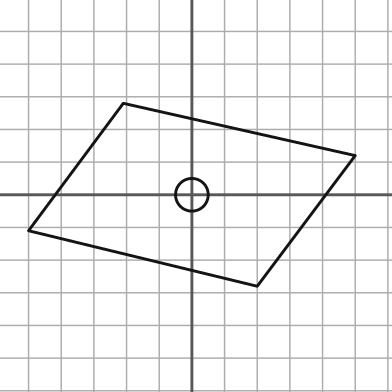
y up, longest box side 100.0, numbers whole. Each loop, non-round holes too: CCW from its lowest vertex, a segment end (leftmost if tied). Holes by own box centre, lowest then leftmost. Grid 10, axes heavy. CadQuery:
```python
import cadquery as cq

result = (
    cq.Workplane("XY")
    .moveTo(20.0, -28.0)
    .lineTo(50.0, 12.0)
    .lineTo(-21.0, 28.0)
    .lineTo(-50.0, -11.0)
    .close()
    .moveTo(0.0, 0.0)
    .circle(5.0)
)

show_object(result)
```